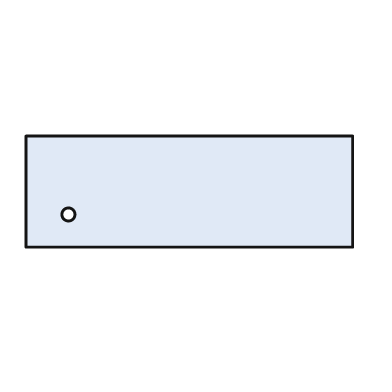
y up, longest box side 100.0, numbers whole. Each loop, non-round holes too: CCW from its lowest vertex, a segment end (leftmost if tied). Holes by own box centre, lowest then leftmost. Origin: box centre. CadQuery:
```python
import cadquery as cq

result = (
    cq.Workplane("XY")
    .moveTo(-50.0, -17.0)
    .lineTo(50.0, -17.0)
    .lineTo(50.0, 17.0)
    .lineTo(-50.0, 17.0)
    .close()
    .moveTo(-37.0, -7.0)
    .circle(2.0)
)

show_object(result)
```